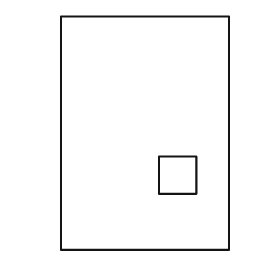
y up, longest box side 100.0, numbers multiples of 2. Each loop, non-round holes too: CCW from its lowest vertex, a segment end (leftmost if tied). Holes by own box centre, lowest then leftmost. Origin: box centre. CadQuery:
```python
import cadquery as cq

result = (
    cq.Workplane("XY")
    .moveTo(-36.0, -50.0)
    .lineTo(36.0, -50.0)
    .lineTo(36.0, 50.0)
    .lineTo(-36.0, 50.0)
    .close()
    .moveTo(6.0, -26.0)
    .lineTo(22.0, -26.0)
    .lineTo(22.0, -10.0)
    .lineTo(6.0, -10.0)
    .close()
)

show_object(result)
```